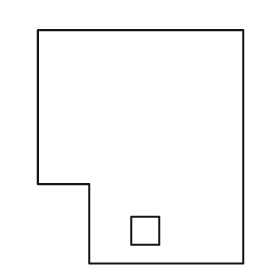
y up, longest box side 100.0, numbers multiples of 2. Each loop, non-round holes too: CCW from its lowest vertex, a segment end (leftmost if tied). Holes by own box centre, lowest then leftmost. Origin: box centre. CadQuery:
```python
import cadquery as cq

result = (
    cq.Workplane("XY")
    .moveTo(-22.0, -50.0)
    .lineTo(44.0, -50.0)
    .lineTo(44.0, 50.0)
    .lineTo(-44.0, 50.0)
    .lineTo(-44.0, -16.0)
    .lineTo(-22.0, -16.0)
    .close()
    .moveTo(-4.0, -42.0)
    .lineTo(8.0, -42.0)
    .lineTo(8.0, -30.0)
    .lineTo(-4.0, -30.0)
    .close()
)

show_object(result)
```